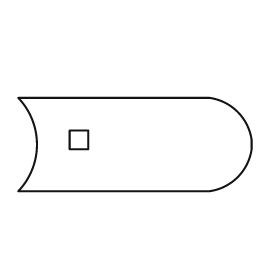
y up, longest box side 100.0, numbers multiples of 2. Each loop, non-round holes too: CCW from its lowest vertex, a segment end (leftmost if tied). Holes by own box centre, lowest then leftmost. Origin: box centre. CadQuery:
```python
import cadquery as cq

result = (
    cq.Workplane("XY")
    .moveTo(-50.0, -20.0)
    .lineTo(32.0, -20.0)
    .threePointArc((44.0, -14.0), (50.0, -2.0))
    .lineTo(50.0, 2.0)
    .threePointArc((44.0, 14.0), (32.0, 20.0))
    .lineTo(-50.0, 20.0)
    .threePointArc((-42.0, 0.0), (-50.0, -20.0))
    .close()
    .moveTo(-28.0, -2.0)
    .lineTo(-20.0, -2.0)
    .lineTo(-20.0, 6.0)
    .lineTo(-28.0, 6.0)
    .close()
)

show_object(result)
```